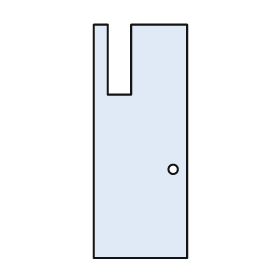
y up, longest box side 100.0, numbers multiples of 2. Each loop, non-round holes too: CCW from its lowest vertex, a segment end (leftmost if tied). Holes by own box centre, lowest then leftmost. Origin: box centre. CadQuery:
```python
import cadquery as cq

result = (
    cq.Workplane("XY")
    .moveTo(-20.0, -50.0)
    .lineTo(20.0, -50.0)
    .lineTo(20.0, 50.0)
    .lineTo(-4.0, 50.0)
    .lineTo(-4.0, 20.0)
    .lineTo(-14.0, 20.0)
    .lineTo(-14.0, 50.0)
    .lineTo(-20.0, 50.0)
    .close()
    .moveTo(14.0, -12.0)
    .circle(2.0)
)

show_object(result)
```